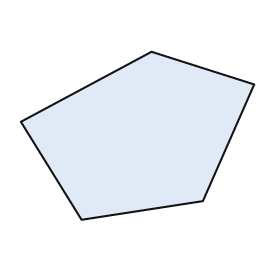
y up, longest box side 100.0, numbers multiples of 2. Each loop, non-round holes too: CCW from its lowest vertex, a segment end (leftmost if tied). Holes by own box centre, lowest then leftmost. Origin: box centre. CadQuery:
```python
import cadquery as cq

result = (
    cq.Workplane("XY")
    .moveTo(-24.0, -36.0)
    .lineTo(28.0, -28.0)
    .lineTo(50.0, 22.0)
    .lineTo(6.0, 36.0)
    .lineTo(-50.0, 6.0)
    .close()
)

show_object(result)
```